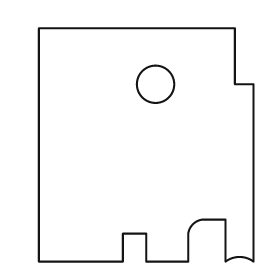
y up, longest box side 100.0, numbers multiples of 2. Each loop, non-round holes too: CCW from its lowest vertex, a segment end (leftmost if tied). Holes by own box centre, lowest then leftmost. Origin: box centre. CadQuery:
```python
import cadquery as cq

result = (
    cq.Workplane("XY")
    .moveTo(-46.0, -50.0)
    .lineTo(-10.0, -50.0)
    .lineTo(-10.0, -38.0)
    .lineTo(0.0, -38.0)
    .lineTo(0.0, -50.0)
    .lineTo(18.0, -50.0)
    .lineTo(18.0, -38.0)
    .threePointArc((20.0, -34.0), (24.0, -32.0))
    .lineTo(34.0, -32.0)
    .lineTo(34.0, -50.0)
    .threePointArc((40.0, -48.0), (46.0, -50.0))
    .lineTo(46.0, 26.0)
    .lineTo(38.0, 26.0)
    .lineTo(38.0, 50.0)
    .lineTo(-46.0, 50.0)
    .close()
    .moveTo(4.0, 26.0)
    .circle(8.0)
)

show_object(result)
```